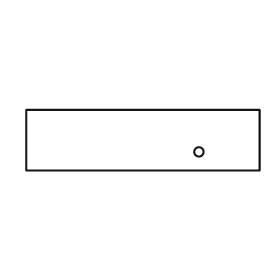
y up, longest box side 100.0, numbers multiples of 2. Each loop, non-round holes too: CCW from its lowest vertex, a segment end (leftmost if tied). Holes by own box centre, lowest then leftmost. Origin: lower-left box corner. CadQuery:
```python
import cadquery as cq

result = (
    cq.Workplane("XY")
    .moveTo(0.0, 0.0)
    .lineTo(100.0, 0.0)
    .lineTo(100.0, 26.0)
    .lineTo(0.0, 26.0)
    .close()
    .moveTo(74.0, 8.0)
    .circle(2.0)
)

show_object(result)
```